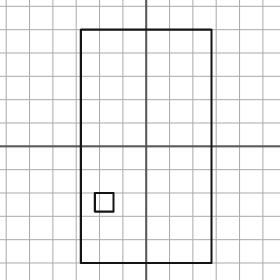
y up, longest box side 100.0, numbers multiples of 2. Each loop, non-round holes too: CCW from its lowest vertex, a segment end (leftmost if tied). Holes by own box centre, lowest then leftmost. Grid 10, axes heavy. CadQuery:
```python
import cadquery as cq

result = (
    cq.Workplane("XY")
    .moveTo(-28.0, -50.0)
    .lineTo(28.0, -50.0)
    .lineTo(28.0, 50.0)
    .lineTo(-28.0, 50.0)
    .close()
    .moveTo(-22.0, -28.0)
    .lineTo(-14.0, -28.0)
    .lineTo(-14.0, -20.0)
    .lineTo(-22.0, -20.0)
    .close()
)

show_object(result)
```